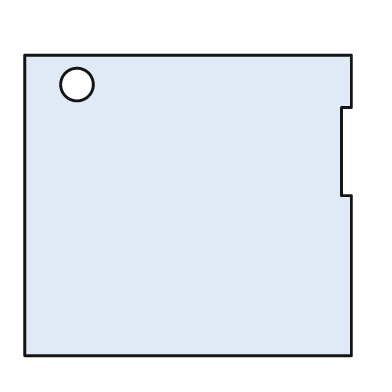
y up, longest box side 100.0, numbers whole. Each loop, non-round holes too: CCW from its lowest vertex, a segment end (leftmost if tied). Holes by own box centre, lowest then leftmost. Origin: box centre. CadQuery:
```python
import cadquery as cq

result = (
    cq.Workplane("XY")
    .moveTo(-50.0, -46.0)
    .lineTo(50.0, -46.0)
    .lineTo(50.0, 3.0)
    .lineTo(47.0, 3.0)
    .lineTo(47.0, 30.0)
    .lineTo(50.0, 30.0)
    .lineTo(50.0, 46.0)
    .lineTo(-50.0, 46.0)
    .close()
    .moveTo(-34.0, 37.0)
    .circle(5.0)
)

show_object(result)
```